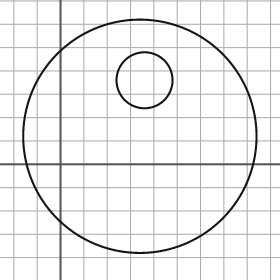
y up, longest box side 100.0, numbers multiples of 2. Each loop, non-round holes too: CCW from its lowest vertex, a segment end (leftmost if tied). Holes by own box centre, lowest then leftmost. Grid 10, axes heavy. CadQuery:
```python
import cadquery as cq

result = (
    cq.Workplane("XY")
    .moveTo(34.0, 12.0)
    .circle(50.0)
    .moveTo(36.0, 36.0)
    .circle(12.0)
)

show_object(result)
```